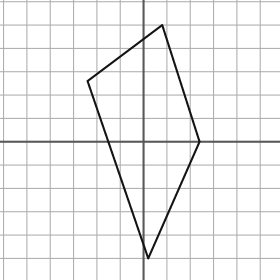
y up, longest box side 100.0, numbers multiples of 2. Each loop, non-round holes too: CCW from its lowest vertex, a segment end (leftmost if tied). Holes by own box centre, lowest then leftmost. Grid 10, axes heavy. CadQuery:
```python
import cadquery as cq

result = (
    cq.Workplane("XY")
    .moveTo(2.0, -50.0)
    .lineTo(24.0, 0.0)
    .lineTo(8.0, 50.0)
    .lineTo(-24.0, 26.0)
    .close()
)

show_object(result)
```